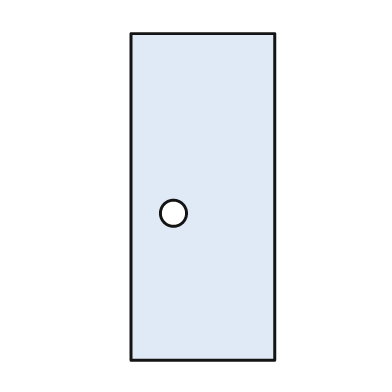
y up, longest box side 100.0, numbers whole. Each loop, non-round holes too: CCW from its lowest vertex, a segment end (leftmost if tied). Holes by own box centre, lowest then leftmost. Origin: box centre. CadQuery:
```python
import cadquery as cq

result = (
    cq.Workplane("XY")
    .moveTo(-22.0, -50.0)
    .lineTo(22.0, -50.0)
    .lineTo(22.0, 50.0)
    .lineTo(-22.0, 50.0)
    .close()
    .moveTo(-9.0, -5.0)
    .circle(4.0)
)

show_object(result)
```